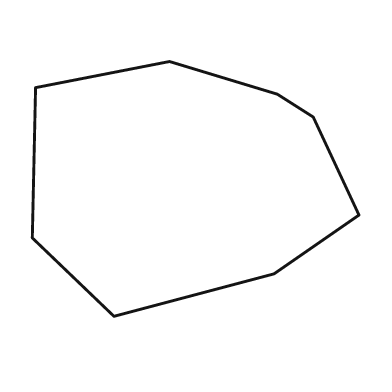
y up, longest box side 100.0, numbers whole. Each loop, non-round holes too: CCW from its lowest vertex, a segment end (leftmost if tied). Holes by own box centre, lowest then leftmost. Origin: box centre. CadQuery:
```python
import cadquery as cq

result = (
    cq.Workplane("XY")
    .moveTo(-25.0, -39.0)
    .lineTo(24.0, -26.0)
    .lineTo(50.0, -8.0)
    .lineTo(36.0, 22.0)
    .lineTo(25.0, 29.0)
    .lineTo(-8.0, 39.0)
    .lineTo(-49.0, 31.0)
    .lineTo(-50.0, -15.0)
    .close()
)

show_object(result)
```